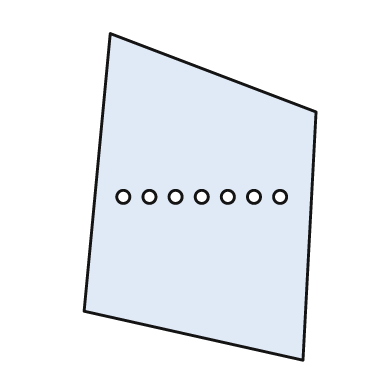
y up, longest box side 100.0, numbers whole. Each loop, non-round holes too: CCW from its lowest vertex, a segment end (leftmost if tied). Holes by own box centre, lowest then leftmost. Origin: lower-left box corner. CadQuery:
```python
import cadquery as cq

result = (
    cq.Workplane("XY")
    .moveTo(67.0, 0.0)
    .lineTo(71.0, 76.0)
    .lineTo(8.0, 100.0)
    .lineTo(0.0, 15.0)
    .close()
    .moveTo(12.0, 50.0)
    .circle(2.0)
    .moveTo(20.0, 50.0)
    .circle(2.0)
    .moveTo(28.0, 50.0)
    .circle(2.0)
    .moveTo(36.0, 50.0)
    .circle(2.0)
    .moveTo(44.0, 50.0)
    .circle(2.0)
    .moveTo(52.0, 50.0)
    .circle(2.0)
    .moveTo(60.0, 50.0)
    .circle(2.0)
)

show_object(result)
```